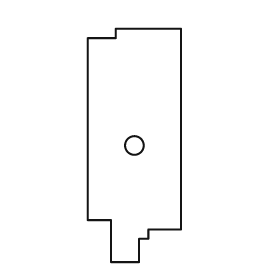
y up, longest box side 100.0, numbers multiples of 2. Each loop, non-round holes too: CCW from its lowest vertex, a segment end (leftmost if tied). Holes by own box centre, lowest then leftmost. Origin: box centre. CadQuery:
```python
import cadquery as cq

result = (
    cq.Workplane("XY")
    .moveTo(-10.0, -50.0)
    .lineTo(2.0, -50.0)
    .lineTo(2.0, -40.0)
    .lineTo(6.0, -40.0)
    .lineTo(6.0, -36.0)
    .lineTo(20.0, -36.0)
    .lineTo(20.0, 50.0)
    .lineTo(-8.0, 50.0)
    .lineTo(-8.0, 46.0)
    .lineTo(-20.0, 46.0)
    .lineTo(-20.0, -32.0)
    .lineTo(-10.0, -32.0)
    .close()
    .moveTo(0.0, 0.0)
    .circle(4.0)
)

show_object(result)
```